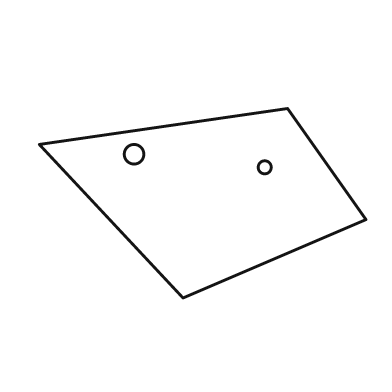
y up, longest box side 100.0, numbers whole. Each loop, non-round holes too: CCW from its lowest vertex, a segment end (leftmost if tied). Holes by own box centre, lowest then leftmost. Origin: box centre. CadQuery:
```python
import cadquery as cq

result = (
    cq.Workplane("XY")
    .moveTo(-6.0, -29.0)
    .lineTo(50.0, -5.0)
    .lineTo(26.0, 29.0)
    .lineTo(-50.0, 18.0)
    .close()
    .moveTo(19.0, 11.0)
    .circle(2.0)
    .moveTo(-21.0, 15.0)
    .circle(3.0)
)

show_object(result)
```